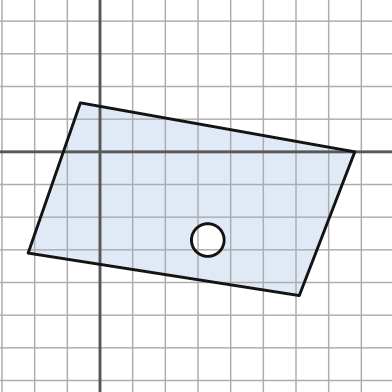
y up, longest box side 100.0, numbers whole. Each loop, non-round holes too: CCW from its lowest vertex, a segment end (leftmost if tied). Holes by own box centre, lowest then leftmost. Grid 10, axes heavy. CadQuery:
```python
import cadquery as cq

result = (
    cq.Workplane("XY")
    .moveTo(61.0, -44.0)
    .lineTo(78.0, 0.0)
    .lineTo(-6.0, 15.0)
    .lineTo(-22.0, -31.0)
    .close()
    .moveTo(33.0, -27.0)
    .circle(5.0)
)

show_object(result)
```